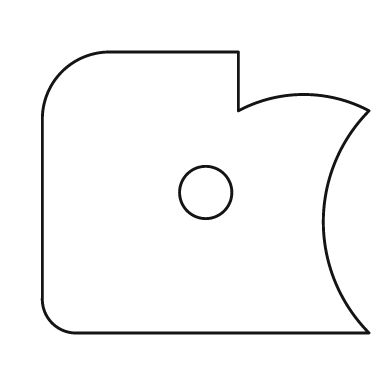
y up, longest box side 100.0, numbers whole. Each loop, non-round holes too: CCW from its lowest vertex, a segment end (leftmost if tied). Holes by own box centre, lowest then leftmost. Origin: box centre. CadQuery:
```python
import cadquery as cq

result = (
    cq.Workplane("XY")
    .moveTo(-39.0, -43.0)
    .lineTo(50.0, -43.0)
    .threePointArc((36.0, -9.0), (50.0, 25.0))
    .threePointArc((30.0, 30.0), (10.0, 25.0))
    .lineTo(10.0, 43.0)
    .lineTo(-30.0, 43.0)
    .threePointArc((-44.0, 37.0), (-50.0, 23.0))
    .lineTo(-50.0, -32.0)
    .threePointArc((-47.0, -40.0), (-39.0, -43.0))
    .close()
    .moveTo(0.0, 0.0)
    .circle(8.0)
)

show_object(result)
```